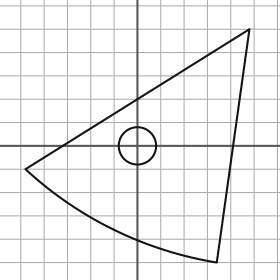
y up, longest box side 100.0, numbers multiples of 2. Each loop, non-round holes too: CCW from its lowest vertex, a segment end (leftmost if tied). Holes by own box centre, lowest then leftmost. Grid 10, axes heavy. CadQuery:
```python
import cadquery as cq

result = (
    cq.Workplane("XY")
    .moveTo(34.0, -50.0)
    .lineTo(48.0, 50.0)
    .lineTo(-48.0, -10.0)
    .threePointArc((-10.0, -36.0), (34.0, -50.0))
    .close()
    .moveTo(0.0, 0.0)
    .circle(8.0)
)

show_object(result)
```